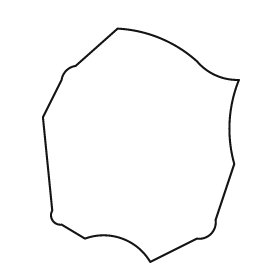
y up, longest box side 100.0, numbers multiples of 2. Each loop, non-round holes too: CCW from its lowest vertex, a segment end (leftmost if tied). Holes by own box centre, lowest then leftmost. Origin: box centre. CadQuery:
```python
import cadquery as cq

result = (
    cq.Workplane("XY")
    .moveTo(4.0, -50.0)
    .lineTo(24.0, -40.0)
    .threePointArc((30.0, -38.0), (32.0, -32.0))
    .lineTo(40.0, -8.0)
    .threePointArc((38.0, 10.0), (42.0, 28.0))
    .threePointArc((32.0, 30.0), (24.0, 36.0))
    .threePointArc((8.0, 46.0), (-10.0, 50.0))
    .lineTo(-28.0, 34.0)
    .threePointArc((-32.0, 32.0), (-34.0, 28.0))
    .lineTo(-42.0, 12.0)
    .lineTo(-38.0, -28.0)
    .threePointArc((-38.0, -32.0), (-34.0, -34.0))
    .lineTo(-24.0, -40.0)
    .threePointArc((-8.0, -40.0), (4.0, -50.0))
    .close()
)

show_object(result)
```